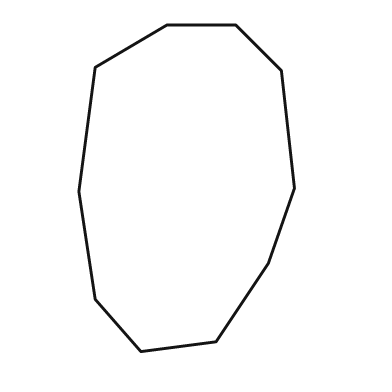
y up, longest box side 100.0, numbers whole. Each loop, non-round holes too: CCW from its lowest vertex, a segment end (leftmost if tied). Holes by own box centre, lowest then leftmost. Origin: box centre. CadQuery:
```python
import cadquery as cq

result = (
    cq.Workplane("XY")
    .moveTo(-14.0, -50.0)
    .lineTo(9.0, -47.0)
    .lineTo(25.0, -23.0)
    .lineTo(33.0, 0.0)
    .lineTo(29.0, 36.0)
    .lineTo(15.0, 50.0)
    .lineTo(-6.0, 50.0)
    .lineTo(-28.0, 37.0)
    .lineTo(-33.0, -1.0)
    .lineTo(-28.0, -34.0)
    .close()
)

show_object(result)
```